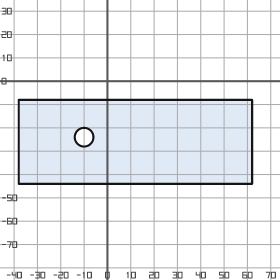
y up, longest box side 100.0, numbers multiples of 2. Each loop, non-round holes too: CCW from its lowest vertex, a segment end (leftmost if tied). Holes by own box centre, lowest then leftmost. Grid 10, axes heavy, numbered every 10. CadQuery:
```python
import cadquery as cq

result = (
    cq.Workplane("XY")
    .moveTo(-38.0, -44.0)
    .lineTo(62.0, -44.0)
    .lineTo(62.0, -8.0)
    .lineTo(-38.0, -8.0)
    .close()
    .moveTo(-10.0, -24.0)
    .circle(4.0)
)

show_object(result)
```